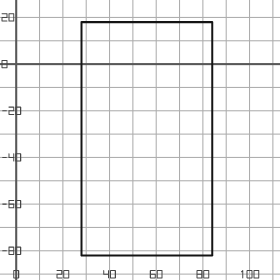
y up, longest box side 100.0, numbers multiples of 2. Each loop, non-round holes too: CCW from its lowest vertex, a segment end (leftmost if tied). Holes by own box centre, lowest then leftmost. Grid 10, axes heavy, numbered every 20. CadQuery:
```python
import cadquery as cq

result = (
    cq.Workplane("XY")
    .moveTo(28.0, -82.0)
    .lineTo(84.0, -82.0)
    .lineTo(84.0, 18.0)
    .lineTo(28.0, 18.0)
    .close()
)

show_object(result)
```